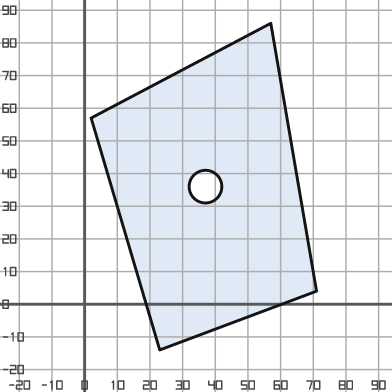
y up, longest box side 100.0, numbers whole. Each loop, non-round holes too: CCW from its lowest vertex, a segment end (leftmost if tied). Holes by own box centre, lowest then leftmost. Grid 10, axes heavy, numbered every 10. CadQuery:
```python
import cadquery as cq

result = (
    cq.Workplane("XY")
    .moveTo(23.0, -14.0)
    .lineTo(71.0, 4.0)
    .lineTo(57.0, 86.0)
    .lineTo(2.0, 57.0)
    .close()
    .moveTo(37.0, 36.0)
    .circle(5.0)
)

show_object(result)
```